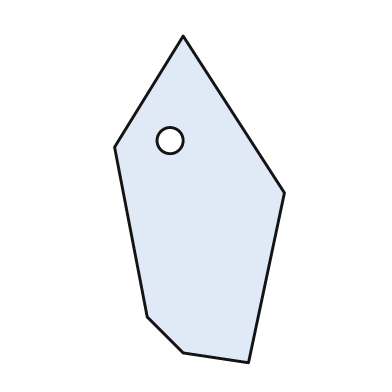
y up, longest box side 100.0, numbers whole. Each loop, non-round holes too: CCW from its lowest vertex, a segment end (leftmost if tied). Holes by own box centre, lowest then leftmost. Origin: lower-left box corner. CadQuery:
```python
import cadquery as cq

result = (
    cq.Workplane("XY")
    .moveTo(41.0, 0.0)
    .lineTo(52.0, 52.0)
    .lineTo(21.0, 100.0)
    .lineTo(0.0, 66.0)
    .lineTo(10.0, 14.0)
    .lineTo(21.0, 3.0)
    .close()
    .moveTo(17.0, 68.0)
    .circle(4.0)
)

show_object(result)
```